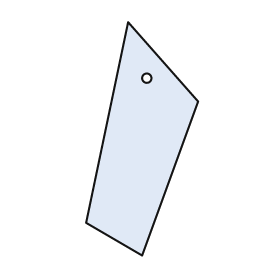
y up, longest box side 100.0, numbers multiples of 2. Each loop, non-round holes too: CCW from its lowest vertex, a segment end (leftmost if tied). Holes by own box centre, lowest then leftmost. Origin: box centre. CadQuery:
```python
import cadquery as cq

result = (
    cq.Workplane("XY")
    .moveTo(0.0, -50.0)
    .lineTo(24.0, 16.0)
    .lineTo(-6.0, 50.0)
    .lineTo(-24.0, -36.0)
    .close()
    .moveTo(2.0, 26.0)
    .circle(2.0)
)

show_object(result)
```